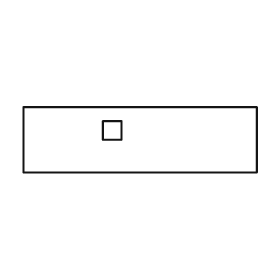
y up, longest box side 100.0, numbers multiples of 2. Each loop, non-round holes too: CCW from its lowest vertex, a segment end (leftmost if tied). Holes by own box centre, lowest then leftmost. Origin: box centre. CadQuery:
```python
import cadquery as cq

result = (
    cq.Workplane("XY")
    .moveTo(-50.0, -14.0)
    .lineTo(50.0, -14.0)
    .lineTo(50.0, 14.0)
    .lineTo(-50.0, 14.0)
    .close()
    .moveTo(-16.0, 0.0)
    .lineTo(-8.0, 0.0)
    .lineTo(-8.0, 8.0)
    .lineTo(-16.0, 8.0)
    .close()
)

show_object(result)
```